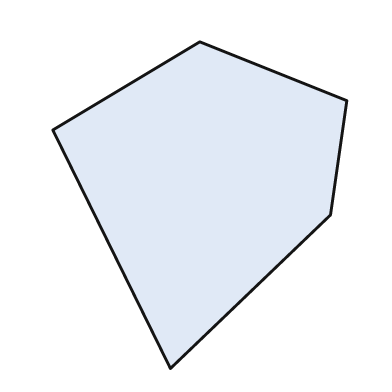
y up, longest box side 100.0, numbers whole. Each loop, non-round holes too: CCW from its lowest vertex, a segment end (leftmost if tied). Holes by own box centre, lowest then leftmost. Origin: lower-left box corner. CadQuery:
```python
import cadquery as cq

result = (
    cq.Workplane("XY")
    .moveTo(36.0, 0.0)
    .lineTo(85.0, 47.0)
    .lineTo(90.0, 82.0)
    .lineTo(45.0, 100.0)
    .lineTo(0.0, 73.0)
    .close()
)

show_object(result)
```